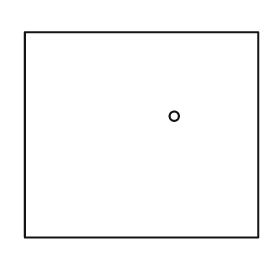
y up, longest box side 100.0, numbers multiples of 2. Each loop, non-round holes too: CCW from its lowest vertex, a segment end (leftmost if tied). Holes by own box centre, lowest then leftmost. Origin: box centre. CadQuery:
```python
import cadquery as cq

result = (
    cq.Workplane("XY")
    .moveTo(-50.0, -44.0)
    .lineTo(50.0, -44.0)
    .lineTo(50.0, 44.0)
    .lineTo(-50.0, 44.0)
    .close()
    .moveTo(14.0, 8.0)
    .circle(2.0)
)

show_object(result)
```